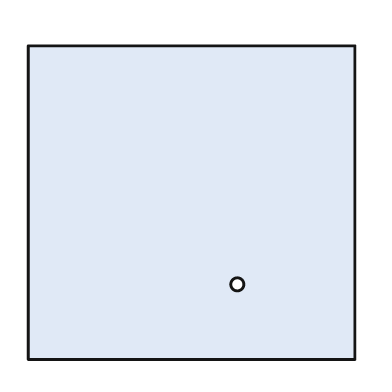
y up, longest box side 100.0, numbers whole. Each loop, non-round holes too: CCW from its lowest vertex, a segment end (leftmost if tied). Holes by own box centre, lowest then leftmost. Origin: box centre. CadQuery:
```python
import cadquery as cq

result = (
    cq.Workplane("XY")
    .moveTo(-50.0, -48.0)
    .lineTo(50.0, -48.0)
    .lineTo(50.0, 48.0)
    .lineTo(-50.0, 48.0)
    .close()
    .moveTo(14.0, -25.0)
    .circle(2.0)
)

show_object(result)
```